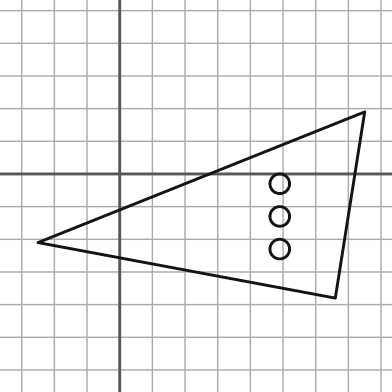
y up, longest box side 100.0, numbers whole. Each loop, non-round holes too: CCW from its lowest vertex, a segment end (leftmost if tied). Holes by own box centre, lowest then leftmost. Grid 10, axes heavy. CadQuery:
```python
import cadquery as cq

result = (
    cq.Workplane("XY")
    .moveTo(66.0, -38.0)
    .lineTo(75.0, 19.0)
    .lineTo(-25.0, -21.0)
    .close()
    .moveTo(49.0, -23.0)
    .circle(3.0)
    .moveTo(49.0, -13.0)
    .circle(3.0)
    .moveTo(49.0, -3.0)
    .circle(3.0)
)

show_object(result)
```